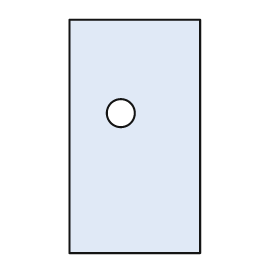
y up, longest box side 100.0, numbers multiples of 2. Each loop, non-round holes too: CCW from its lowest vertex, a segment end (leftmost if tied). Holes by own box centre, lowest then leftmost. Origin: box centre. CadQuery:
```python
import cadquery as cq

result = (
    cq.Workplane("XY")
    .moveTo(-28.0, -50.0)
    .lineTo(28.0, -50.0)
    .lineTo(28.0, 50.0)
    .lineTo(-28.0, 50.0)
    .close()
    .moveTo(-6.0, 10.0)
    .circle(6.0)
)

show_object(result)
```